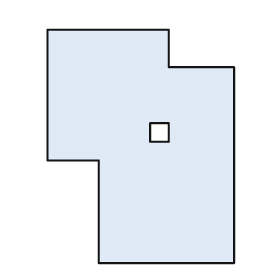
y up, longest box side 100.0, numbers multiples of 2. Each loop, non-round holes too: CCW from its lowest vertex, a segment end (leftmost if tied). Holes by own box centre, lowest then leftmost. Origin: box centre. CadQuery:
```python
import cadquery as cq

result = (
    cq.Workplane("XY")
    .moveTo(-18.0, -50.0)
    .lineTo(40.0, -50.0)
    .lineTo(40.0, 34.0)
    .lineTo(12.0, 34.0)
    .lineTo(12.0, 50.0)
    .lineTo(-40.0, 50.0)
    .lineTo(-40.0, -6.0)
    .lineTo(-18.0, -6.0)
    .close()
    .moveTo(4.0, 2.0)
    .lineTo(12.0, 2.0)
    .lineTo(12.0, 10.0)
    .lineTo(4.0, 10.0)
    .close()
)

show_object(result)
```